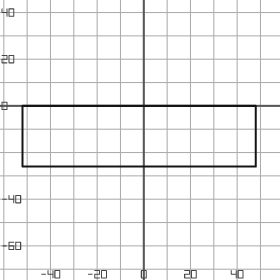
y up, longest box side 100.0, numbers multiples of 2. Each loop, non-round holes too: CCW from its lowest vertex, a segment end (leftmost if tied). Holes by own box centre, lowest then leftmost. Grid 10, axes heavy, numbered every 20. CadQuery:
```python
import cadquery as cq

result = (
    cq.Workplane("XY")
    .moveTo(-52.0, -26.0)
    .lineTo(48.0, -26.0)
    .lineTo(48.0, 0.0)
    .lineTo(-52.0, 0.0)
    .close()
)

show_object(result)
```